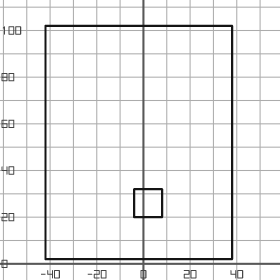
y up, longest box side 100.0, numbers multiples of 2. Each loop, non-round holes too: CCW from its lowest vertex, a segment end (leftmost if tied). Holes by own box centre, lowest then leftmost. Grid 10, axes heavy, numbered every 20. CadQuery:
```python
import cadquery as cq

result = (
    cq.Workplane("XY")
    .moveTo(-42.0, 2.0)
    .lineTo(38.0, 2.0)
    .lineTo(38.0, 102.0)
    .lineTo(-42.0, 102.0)
    .close()
    .moveTo(-4.0, 20.0)
    .lineTo(8.0, 20.0)
    .lineTo(8.0, 32.0)
    .lineTo(-4.0, 32.0)
    .close()
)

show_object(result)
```